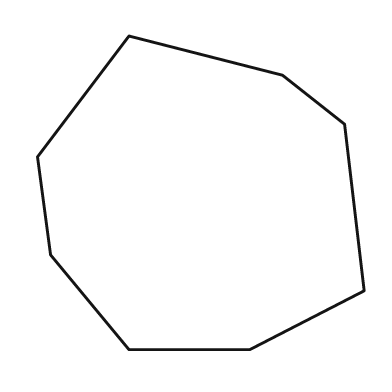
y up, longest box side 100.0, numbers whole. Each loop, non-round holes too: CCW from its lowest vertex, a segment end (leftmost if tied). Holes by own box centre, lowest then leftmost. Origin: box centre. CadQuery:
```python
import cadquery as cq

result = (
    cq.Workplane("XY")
    .moveTo(-22.0, -48.0)
    .lineTo(15.0, -48.0)
    .lineTo(50.0, -30.0)
    .lineTo(44.0, 21.0)
    .lineTo(25.0, 36.0)
    .lineTo(-22.0, 48.0)
    .lineTo(-50.0, 11.0)
    .lineTo(-46.0, -19.0)
    .close()
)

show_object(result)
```